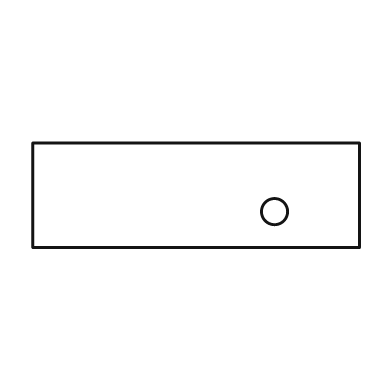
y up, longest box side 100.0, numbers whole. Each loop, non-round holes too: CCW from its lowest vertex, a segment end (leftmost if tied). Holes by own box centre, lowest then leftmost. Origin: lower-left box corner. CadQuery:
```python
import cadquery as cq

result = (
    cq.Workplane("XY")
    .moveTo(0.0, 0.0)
    .lineTo(100.0, 0.0)
    .lineTo(100.0, 32.0)
    .lineTo(0.0, 32.0)
    .close()
    .moveTo(74.0, 11.0)
    .circle(4.0)
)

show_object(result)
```